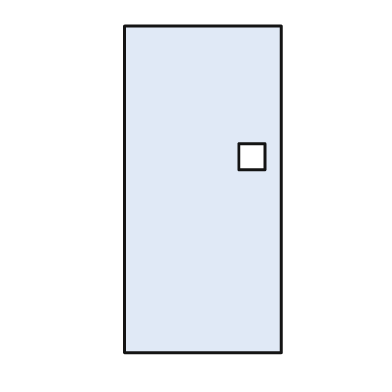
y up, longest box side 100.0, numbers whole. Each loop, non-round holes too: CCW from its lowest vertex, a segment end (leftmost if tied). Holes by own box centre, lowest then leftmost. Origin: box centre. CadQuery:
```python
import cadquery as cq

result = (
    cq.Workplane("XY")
    .moveTo(-24.0, -50.0)
    .lineTo(24.0, -50.0)
    .lineTo(24.0, 50.0)
    .lineTo(-24.0, 50.0)
    .close()
    .moveTo(11.0, 6.0)
    .lineTo(19.0, 6.0)
    .lineTo(19.0, 14.0)
    .lineTo(11.0, 14.0)
    .close()
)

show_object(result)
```